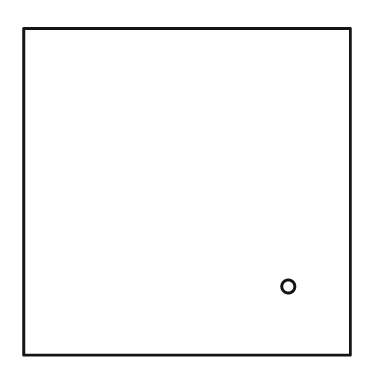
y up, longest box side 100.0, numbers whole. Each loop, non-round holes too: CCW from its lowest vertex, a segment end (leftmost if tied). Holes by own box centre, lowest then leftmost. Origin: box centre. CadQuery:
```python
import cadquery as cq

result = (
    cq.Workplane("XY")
    .moveTo(-50.0, -50.0)
    .lineTo(50.0, -50.0)
    .lineTo(50.0, 50.0)
    .lineTo(-50.0, 50.0)
    .close()
    .moveTo(31.0, -29.0)
    .circle(2.0)
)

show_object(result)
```